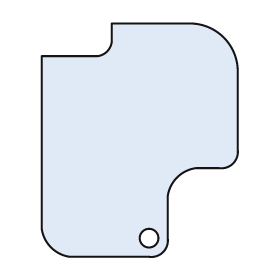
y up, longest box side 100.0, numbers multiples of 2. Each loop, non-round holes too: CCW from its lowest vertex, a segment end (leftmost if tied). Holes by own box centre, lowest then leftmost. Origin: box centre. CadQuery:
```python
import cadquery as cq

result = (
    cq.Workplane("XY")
    .moveTo(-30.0, -50.0)
    .lineTo(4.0, -50.0)
    .threePointArc((10.0, -48.0), (12.0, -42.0))
    .lineTo(12.0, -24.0)
    .threePointArc((16.0, -16.0), (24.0, -12.0))
    .lineTo(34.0, -12.0)
    .threePointArc((40.0, -10.0), (42.0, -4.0))
    .lineTo(42.0, 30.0)
    .threePointArc((36.0, 44.0), (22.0, 50.0))
    .lineTo(-12.0, 50.0)
    .lineTo(-12.0, 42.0)
    .threePointArc((-14.0, 38.0), (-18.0, 36.0))
    .lineTo(-42.0, 36.0)
    .lineTo(-42.0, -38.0)
    .threePointArc((-38.0, -46.0), (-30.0, -50.0))
    .close()
    .moveTo(4.0, -42.0)
    .circle(4.0)
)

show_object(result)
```